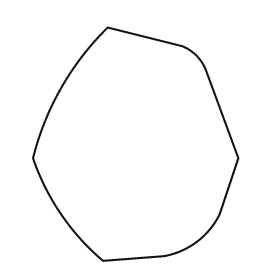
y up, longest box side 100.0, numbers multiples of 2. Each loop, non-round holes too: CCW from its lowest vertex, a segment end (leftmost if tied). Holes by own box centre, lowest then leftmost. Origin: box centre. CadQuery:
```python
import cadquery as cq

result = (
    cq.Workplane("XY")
    .moveTo(-14.0, -50.0)
    .lineTo(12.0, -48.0)
    .threePointArc((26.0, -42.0), (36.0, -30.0))
    .lineTo(44.0, -6.0)
    .lineTo(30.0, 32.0)
    .threePointArc((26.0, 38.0), (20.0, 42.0))
    .lineTo(-12.0, 50.0)
    .threePointArc((-32.0, 24.0), (-44.0, -6.0))
    .threePointArc((-32.0, -30.0), (-14.0, -50.0))
    .close()
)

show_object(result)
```